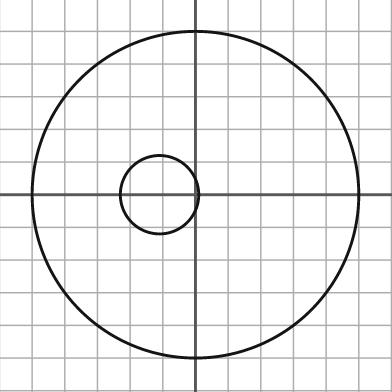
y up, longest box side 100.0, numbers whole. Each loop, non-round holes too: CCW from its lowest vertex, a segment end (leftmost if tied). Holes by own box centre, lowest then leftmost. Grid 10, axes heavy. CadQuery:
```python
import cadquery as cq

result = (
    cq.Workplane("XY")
    .moveTo(0.0, 0.0)
    .circle(50.0)
    .moveTo(-11.0, 0.0)
    .circle(12.0)
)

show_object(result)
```